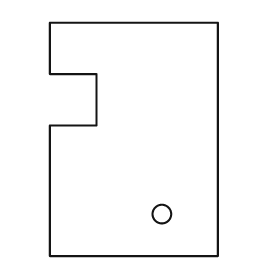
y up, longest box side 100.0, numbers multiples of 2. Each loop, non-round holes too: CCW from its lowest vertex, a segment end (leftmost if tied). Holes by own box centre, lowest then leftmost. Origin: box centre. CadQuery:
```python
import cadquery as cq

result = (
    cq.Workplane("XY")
    .moveTo(-36.0, -50.0)
    .lineTo(36.0, -50.0)
    .lineTo(36.0, 50.0)
    .lineTo(-36.0, 50.0)
    .lineTo(-36.0, 28.0)
    .lineTo(-16.0, 28.0)
    .lineTo(-16.0, 6.0)
    .lineTo(-36.0, 6.0)
    .close()
    .moveTo(12.0, -32.0)
    .circle(4.0)
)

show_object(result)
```